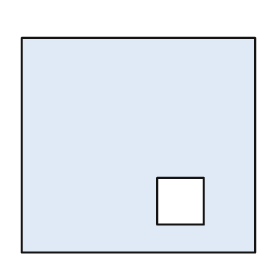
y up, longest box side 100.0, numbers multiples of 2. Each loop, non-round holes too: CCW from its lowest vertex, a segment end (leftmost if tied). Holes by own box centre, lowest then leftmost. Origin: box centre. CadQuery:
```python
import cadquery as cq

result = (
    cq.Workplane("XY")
    .moveTo(-50.0, -46.0)
    .lineTo(50.0, -46.0)
    .lineTo(50.0, 46.0)
    .lineTo(-50.0, 46.0)
    .close()
    .moveTo(8.0, -34.0)
    .lineTo(28.0, -34.0)
    .lineTo(28.0, -14.0)
    .lineTo(8.0, -14.0)
    .close()
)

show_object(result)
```